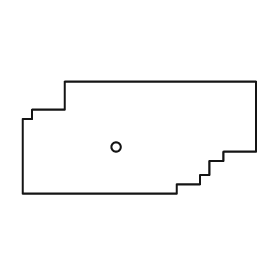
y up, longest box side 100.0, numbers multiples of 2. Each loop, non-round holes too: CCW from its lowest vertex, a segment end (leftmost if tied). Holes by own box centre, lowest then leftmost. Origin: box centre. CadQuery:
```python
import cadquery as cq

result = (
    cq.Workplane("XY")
    .moveTo(-50.0, -24.0)
    .lineTo(16.0, -24.0)
    .lineTo(16.0, -20.0)
    .lineTo(26.0, -20.0)
    .lineTo(26.0, -16.0)
    .lineTo(30.0, -16.0)
    .lineTo(30.0, -10.0)
    .lineTo(36.0, -10.0)
    .lineTo(36.0, -6.0)
    .lineTo(50.0, -6.0)
    .lineTo(50.0, 24.0)
    .lineTo(-32.0, 24.0)
    .lineTo(-32.0, 12.0)
    .lineTo(-46.0, 12.0)
    .lineTo(-46.0, 8.0)
    .lineTo(-50.0, 8.0)
    .close()
    .moveTo(-10.0, -4.0)
    .circle(2.0)
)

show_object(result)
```